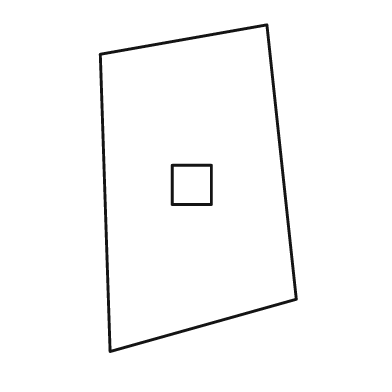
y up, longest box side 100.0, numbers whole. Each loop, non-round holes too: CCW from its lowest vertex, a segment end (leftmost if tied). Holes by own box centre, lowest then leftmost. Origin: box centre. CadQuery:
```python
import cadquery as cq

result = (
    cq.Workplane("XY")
    .moveTo(-27.0, -50.0)
    .lineTo(30.0, -34.0)
    .lineTo(21.0, 50.0)
    .lineTo(-30.0, 41.0)
    .close()
    .moveTo(-8.0, -5.0)
    .lineTo(4.0, -5.0)
    .lineTo(4.0, 7.0)
    .lineTo(-8.0, 7.0)
    .close()
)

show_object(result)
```